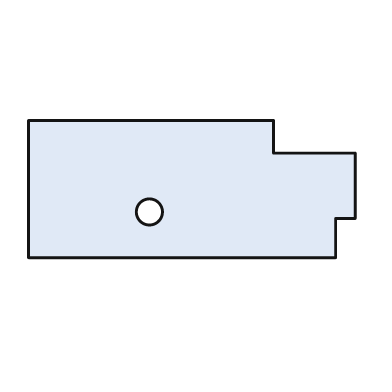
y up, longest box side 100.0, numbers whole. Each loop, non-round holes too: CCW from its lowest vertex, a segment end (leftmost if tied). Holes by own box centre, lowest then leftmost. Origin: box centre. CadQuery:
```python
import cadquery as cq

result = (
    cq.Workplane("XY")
    .moveTo(-50.0, -21.0)
    .lineTo(44.0, -21.0)
    .lineTo(44.0, -9.0)
    .lineTo(50.0, -9.0)
    .lineTo(50.0, 11.0)
    .lineTo(25.0, 11.0)
    .lineTo(25.0, 21.0)
    .lineTo(-50.0, 21.0)
    .close()
    .moveTo(-13.0, -7.0)
    .circle(4.0)
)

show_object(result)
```